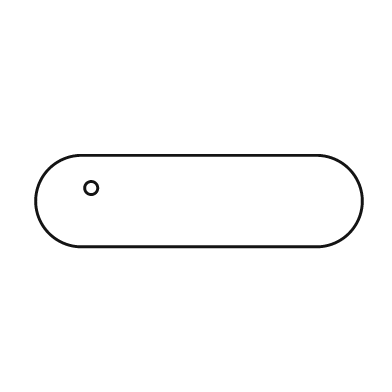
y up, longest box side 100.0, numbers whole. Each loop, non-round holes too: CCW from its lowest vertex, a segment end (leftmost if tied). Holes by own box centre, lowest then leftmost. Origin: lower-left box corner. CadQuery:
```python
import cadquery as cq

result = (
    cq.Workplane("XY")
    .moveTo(14.0, 0.0)
    .lineTo(86.0, 0.0)
    .threePointArc((100.0, 14.0), (86.0, 28.0))
    .lineTo(14.0, 28.0)
    .threePointArc((0.0, 14.0), (14.0, 0.0))
    .close()
    .moveTo(17.0, 18.0)
    .circle(2.0)
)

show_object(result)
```